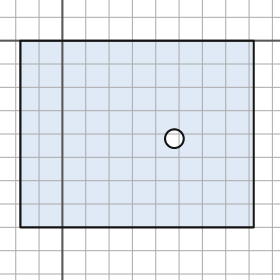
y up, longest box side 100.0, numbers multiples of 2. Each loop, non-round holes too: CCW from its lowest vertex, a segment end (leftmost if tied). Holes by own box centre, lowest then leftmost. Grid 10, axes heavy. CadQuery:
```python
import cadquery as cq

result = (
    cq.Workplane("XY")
    .moveTo(-18.0, -80.0)
    .lineTo(82.0, -80.0)
    .lineTo(82.0, 0.0)
    .lineTo(-18.0, 0.0)
    .close()
    .moveTo(48.0, -42.0)
    .circle(4.0)
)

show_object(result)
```